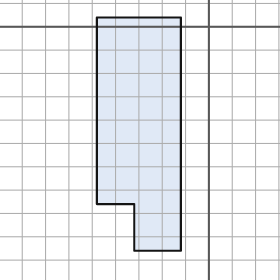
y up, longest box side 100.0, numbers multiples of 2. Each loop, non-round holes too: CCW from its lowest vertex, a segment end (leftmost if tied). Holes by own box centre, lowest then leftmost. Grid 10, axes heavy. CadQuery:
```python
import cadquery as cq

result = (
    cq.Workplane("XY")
    .moveTo(-32.0, -96.0)
    .lineTo(-12.0, -96.0)
    .lineTo(-12.0, 4.0)
    .lineTo(-48.0, 4.0)
    .lineTo(-48.0, -76.0)
    .lineTo(-32.0, -76.0)
    .close()
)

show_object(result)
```